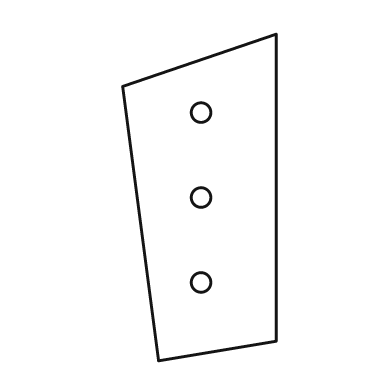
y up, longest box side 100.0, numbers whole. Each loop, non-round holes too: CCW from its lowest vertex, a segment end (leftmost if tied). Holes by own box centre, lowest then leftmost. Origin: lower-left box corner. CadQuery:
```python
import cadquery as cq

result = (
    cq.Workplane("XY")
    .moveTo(11.0, 0.0)
    .lineTo(47.0, 6.0)
    .lineTo(47.0, 100.0)
    .lineTo(0.0, 84.0)
    .close()
    .moveTo(24.0, 24.0)
    .circle(3.0)
    .moveTo(24.0, 50.0)
    .circle(3.0)
    .moveTo(24.0, 76.0)
    .circle(3.0)
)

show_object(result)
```